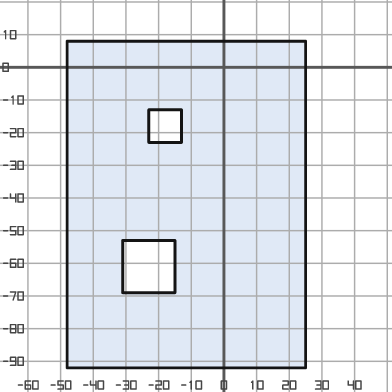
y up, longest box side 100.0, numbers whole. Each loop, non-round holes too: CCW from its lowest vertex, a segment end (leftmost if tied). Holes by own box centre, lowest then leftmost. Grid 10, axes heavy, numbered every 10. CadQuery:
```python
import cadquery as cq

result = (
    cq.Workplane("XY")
    .moveTo(-48.0, -92.0)
    .lineTo(25.0, -92.0)
    .lineTo(25.0, 8.0)
    .lineTo(-48.0, 8.0)
    .close()
    .moveTo(-31.0, -69.0)
    .lineTo(-15.0, -69.0)
    .lineTo(-15.0, -53.0)
    .lineTo(-31.0, -53.0)
    .close()
    .moveTo(-23.0, -23.0)
    .lineTo(-13.0, -23.0)
    .lineTo(-13.0, -13.0)
    .lineTo(-23.0, -13.0)
    .close()
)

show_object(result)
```